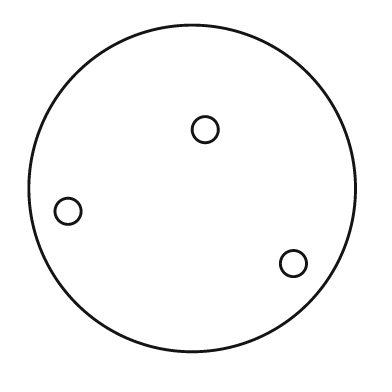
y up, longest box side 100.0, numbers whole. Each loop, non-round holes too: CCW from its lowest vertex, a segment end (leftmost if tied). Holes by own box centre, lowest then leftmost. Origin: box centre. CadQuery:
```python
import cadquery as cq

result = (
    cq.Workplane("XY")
    .moveTo(0.0, 0.0)
    .circle(50.0)
    .moveTo(31.0, -23.0)
    .circle(4.0)
    .moveTo(-38.0, -7.0)
    .circle(4.0)
    .moveTo(4.0, 18.0)
    .circle(4.0)
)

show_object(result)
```